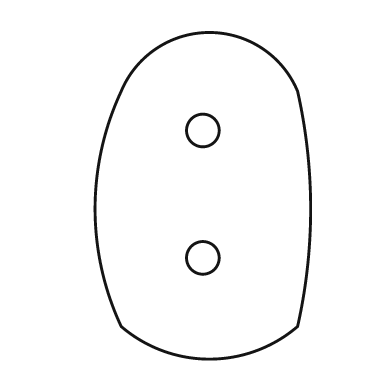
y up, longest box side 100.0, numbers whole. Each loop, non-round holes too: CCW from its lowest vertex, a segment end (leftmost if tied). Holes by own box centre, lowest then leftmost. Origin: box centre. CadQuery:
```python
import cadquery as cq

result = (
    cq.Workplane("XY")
    .moveTo(-25.0, -40.0)
    .threePointArc((2.0, -50.0), (29.0, -40.0))
    .threePointArc((33.0, -4.0), (29.0, 32.0))
    .threePointArc((2.0, 50.0), (-25.0, 32.0))
    .threePointArc((-33.0, -4.0), (-25.0, -40.0))
    .close()
    .moveTo(0.0, -19.0)
    .circle(5.0)
    .moveTo(0.0, 20.0)
    .circle(5.0)
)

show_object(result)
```